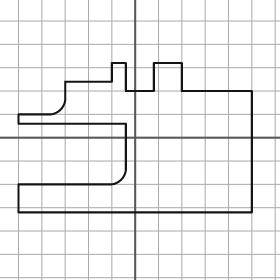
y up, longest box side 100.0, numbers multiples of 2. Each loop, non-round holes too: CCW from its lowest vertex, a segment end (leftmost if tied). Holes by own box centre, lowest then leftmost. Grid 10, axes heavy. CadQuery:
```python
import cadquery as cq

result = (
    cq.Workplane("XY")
    .moveTo(-50.0, -32.0)
    .lineTo(50.0, -32.0)
    .lineTo(50.0, 20.0)
    .lineTo(20.0, 20.0)
    .lineTo(20.0, 32.0)
    .lineTo(8.0, 32.0)
    .lineTo(8.0, 20.0)
    .lineTo(-4.0, 20.0)
    .lineTo(-4.0, 32.0)
    .lineTo(-10.0, 32.0)
    .lineTo(-10.0, 24.0)
    .lineTo(-30.0, 24.0)
    .lineTo(-30.0, 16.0)
    .threePointArc((-32.0, 12.0), (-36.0, 10.0))
    .lineTo(-50.0, 10.0)
    .lineTo(-50.0, 6.0)
    .lineTo(-4.0, 6.0)
    .lineTo(-4.0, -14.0)
    .threePointArc((-6.0, -18.0), (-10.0, -20.0))
    .lineTo(-50.0, -20.0)
    .close()
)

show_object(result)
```